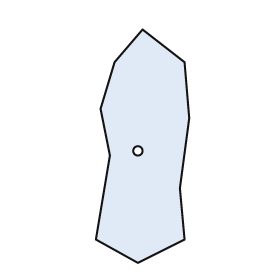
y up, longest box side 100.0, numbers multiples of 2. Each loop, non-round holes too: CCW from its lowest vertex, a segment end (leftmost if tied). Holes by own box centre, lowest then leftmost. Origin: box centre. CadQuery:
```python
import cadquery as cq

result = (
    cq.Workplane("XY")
    .moveTo(-2.0, -50.0)
    .lineTo(18.0, -40.0)
    .lineTo(16.0, -18.0)
    .lineTo(20.0, 12.0)
    .lineTo(18.0, 36.0)
    .lineTo(0.0, 50.0)
    .lineTo(-12.0, 36.0)
    .lineTo(-18.0, 16.0)
    .lineTo(-14.0, -4.0)
    .lineTo(-20.0, -40.0)
    .close()
    .moveTo(-2.0, -2.0)
    .circle(2.0)
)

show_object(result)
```